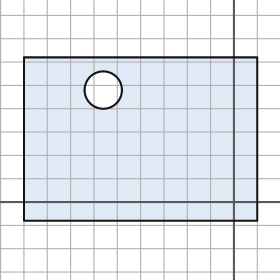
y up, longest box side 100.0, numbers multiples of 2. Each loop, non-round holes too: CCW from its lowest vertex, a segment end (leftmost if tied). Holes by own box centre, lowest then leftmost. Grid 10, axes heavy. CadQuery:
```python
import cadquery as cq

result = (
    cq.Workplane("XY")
    .moveTo(-90.0, -8.0)
    .lineTo(10.0, -8.0)
    .lineTo(10.0, 62.0)
    .lineTo(-90.0, 62.0)
    .close()
    .moveTo(-56.0, 48.0)
    .circle(8.0)
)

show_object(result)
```